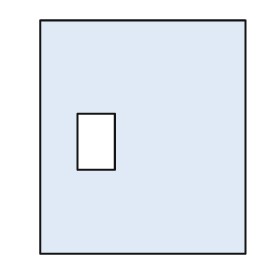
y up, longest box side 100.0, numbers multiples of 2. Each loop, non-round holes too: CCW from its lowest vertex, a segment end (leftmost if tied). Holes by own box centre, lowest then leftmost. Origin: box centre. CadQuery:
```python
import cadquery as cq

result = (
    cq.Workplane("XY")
    .moveTo(-44.0, -50.0)
    .lineTo(44.0, -50.0)
    .lineTo(44.0, 50.0)
    .lineTo(-44.0, 50.0)
    .close()
    .moveTo(-28.0, -14.0)
    .lineTo(-12.0, -14.0)
    .lineTo(-12.0, 10.0)
    .lineTo(-28.0, 10.0)
    .close()
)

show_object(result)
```